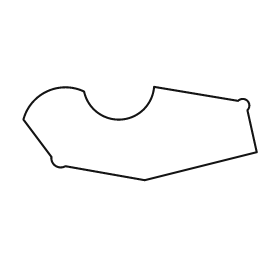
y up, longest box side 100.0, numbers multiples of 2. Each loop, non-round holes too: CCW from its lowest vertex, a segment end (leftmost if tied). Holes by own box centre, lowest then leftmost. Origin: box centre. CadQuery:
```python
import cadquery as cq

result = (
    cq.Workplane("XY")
    .moveTo(2.0, -20.0)
    .lineTo(50.0, -8.0)
    .lineTo(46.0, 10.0)
    .threePointArc((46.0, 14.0), (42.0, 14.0))
    .lineTo(6.0, 20.0)
    .threePointArc((-8.0, 6.0), (-24.0, 18.0))
    .threePointArc((-40.0, 18.0), (-50.0, 6.0))
    .lineTo(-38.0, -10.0)
    .threePointArc((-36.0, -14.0), (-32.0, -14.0))
    .close()
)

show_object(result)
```